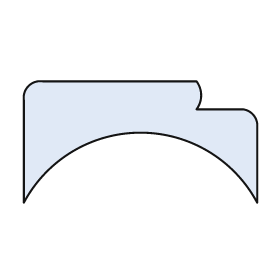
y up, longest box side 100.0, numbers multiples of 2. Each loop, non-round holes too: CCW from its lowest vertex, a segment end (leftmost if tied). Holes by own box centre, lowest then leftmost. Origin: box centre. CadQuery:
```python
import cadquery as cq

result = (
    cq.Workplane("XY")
    .moveTo(-50.0, -26.0)
    .threePointArc((0.0, 4.0), (50.0, -26.0))
    .lineTo(50.0, 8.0)
    .threePointArc((48.0, 12.0), (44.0, 14.0))
    .lineTo(24.0, 14.0)
    .threePointArc((26.0, 20.0), (24.0, 26.0))
    .lineTo(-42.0, 26.0)
    .threePointArc((-48.0, 24.0), (-50.0, 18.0))
    .close()
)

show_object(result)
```